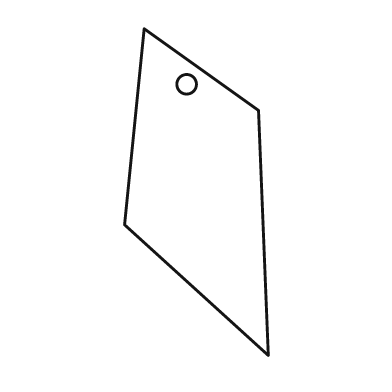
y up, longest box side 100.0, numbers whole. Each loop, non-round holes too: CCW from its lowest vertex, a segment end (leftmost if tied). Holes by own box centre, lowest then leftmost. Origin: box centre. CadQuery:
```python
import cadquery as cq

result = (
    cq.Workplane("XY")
    .moveTo(22.0, -50.0)
    .lineTo(19.0, 25.0)
    .lineTo(-16.0, 50.0)
    .lineTo(-22.0, -10.0)
    .close()
    .moveTo(-3.0, 33.0)
    .circle(3.0)
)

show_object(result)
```